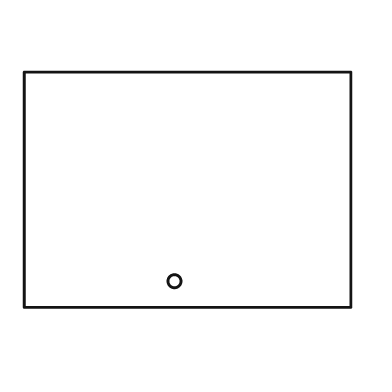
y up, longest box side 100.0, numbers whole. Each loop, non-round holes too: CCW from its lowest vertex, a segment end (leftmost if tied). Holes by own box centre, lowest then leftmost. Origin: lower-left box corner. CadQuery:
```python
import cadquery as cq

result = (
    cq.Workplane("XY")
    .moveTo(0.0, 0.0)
    .lineTo(100.0, 0.0)
    .lineTo(100.0, 72.0)
    .lineTo(0.0, 72.0)
    .close()
    .moveTo(46.0, 8.0)
    .circle(2.0)
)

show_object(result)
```